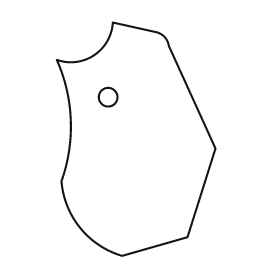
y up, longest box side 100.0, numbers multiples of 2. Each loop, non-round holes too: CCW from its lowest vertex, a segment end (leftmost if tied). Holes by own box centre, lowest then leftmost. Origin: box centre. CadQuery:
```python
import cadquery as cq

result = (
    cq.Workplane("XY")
    .moveTo(-6.0, -50.0)
    .lineTo(22.0, -42.0)
    .lineTo(34.0, -4.0)
    .lineTo(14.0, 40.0)
    .threePointArc((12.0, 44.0), (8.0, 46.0))
    .lineTo(-10.0, 50.0)
    .threePointArc((-18.0, 36.0), (-34.0, 34.0))
    .threePointArc((-28.0, 8.0), (-32.0, -18.0))
    .threePointArc((-24.0, -38.0), (-6.0, -50.0))
    .close()
    .moveTo(-12.0, 18.0)
    .circle(4.0)
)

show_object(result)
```